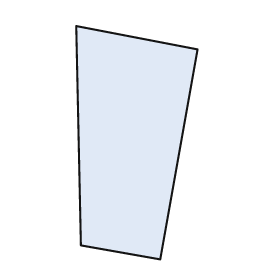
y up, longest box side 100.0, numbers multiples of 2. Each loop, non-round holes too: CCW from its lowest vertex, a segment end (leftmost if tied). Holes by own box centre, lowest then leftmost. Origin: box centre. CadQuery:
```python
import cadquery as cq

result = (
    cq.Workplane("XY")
    .moveTo(10.0, -50.0)
    .lineTo(26.0, 40.0)
    .lineTo(-26.0, 50.0)
    .lineTo(-24.0, -44.0)
    .close()
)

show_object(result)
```